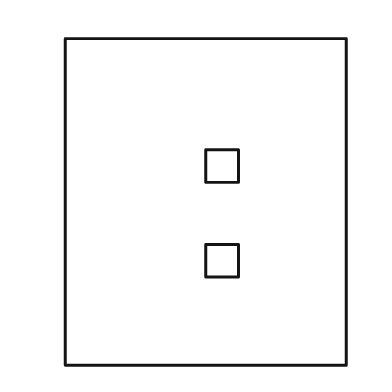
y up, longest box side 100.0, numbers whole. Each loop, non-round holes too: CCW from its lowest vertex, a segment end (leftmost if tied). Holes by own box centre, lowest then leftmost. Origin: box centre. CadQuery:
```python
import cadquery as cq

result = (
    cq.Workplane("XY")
    .moveTo(-43.0, -50.0)
    .lineTo(43.0, -50.0)
    .lineTo(43.0, 50.0)
    .lineTo(-43.0, 50.0)
    .close()
    .moveTo(0.0, -23.0)
    .lineTo(10.0, -23.0)
    .lineTo(10.0, -13.0)
    .lineTo(0.0, -13.0)
    .close()
    .moveTo(0.0, 6.0)
    .lineTo(10.0, 6.0)
    .lineTo(10.0, 16.0)
    .lineTo(0.0, 16.0)
    .close()
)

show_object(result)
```